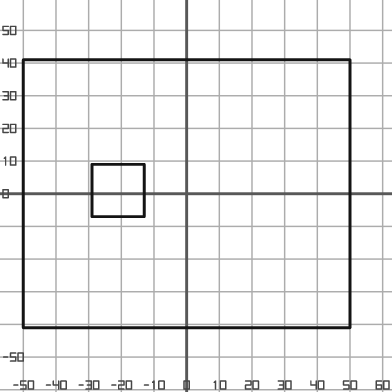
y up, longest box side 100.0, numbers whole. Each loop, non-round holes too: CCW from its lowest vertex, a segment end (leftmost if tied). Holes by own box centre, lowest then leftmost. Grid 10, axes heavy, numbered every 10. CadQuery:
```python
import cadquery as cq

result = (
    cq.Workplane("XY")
    .moveTo(-50.0, -41.0)
    .lineTo(50.0, -41.0)
    .lineTo(50.0, 41.0)
    .lineTo(-50.0, 41.0)
    .close()
    .moveTo(-29.0, -7.0)
    .lineTo(-13.0, -7.0)
    .lineTo(-13.0, 9.0)
    .lineTo(-29.0, 9.0)
    .close()
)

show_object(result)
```